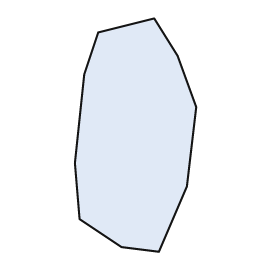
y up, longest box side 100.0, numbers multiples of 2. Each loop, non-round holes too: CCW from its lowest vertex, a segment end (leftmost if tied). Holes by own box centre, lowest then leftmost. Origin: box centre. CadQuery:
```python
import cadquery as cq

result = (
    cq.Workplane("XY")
    .moveTo(10.0, -50.0)
    .lineTo(22.0, -22.0)
    .lineTo(26.0, 12.0)
    .lineTo(18.0, 34.0)
    .lineTo(8.0, 50.0)
    .lineTo(-16.0, 44.0)
    .lineTo(-22.0, 26.0)
    .lineTo(-26.0, -12.0)
    .lineTo(-24.0, -36.0)
    .lineTo(-6.0, -48.0)
    .close()
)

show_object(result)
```